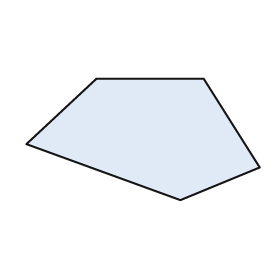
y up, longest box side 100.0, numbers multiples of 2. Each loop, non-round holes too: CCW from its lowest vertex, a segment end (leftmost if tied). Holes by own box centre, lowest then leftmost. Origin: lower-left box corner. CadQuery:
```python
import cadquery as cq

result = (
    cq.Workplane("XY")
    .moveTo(66.0, 0.0)
    .lineTo(100.0, 14.0)
    .lineTo(76.0, 52.0)
    .lineTo(30.0, 52.0)
    .lineTo(0.0, 24.0)
    .close()
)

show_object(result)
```